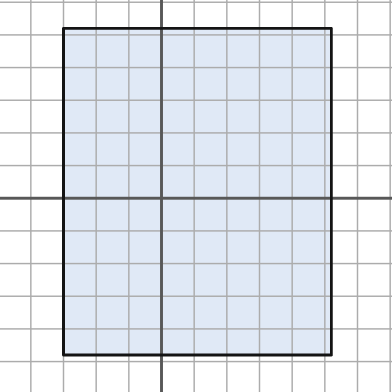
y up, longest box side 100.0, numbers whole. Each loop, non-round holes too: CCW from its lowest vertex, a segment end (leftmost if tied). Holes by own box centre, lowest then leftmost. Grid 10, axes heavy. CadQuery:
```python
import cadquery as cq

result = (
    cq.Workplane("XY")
    .moveTo(-30.0, -48.0)
    .lineTo(52.0, -48.0)
    .lineTo(52.0, 52.0)
    .lineTo(-30.0, 52.0)
    .close()
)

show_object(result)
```